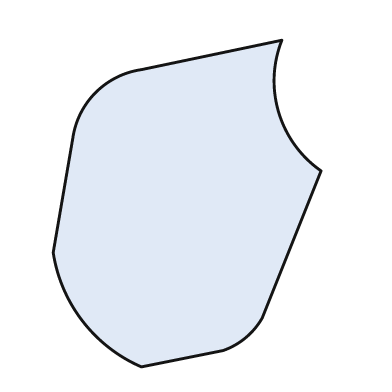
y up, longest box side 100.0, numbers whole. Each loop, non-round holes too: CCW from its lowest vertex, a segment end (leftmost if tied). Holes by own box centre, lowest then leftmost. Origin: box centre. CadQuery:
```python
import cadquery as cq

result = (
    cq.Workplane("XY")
    .moveTo(-14.0, -50.0)
    .lineTo(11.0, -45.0)
    .threePointArc((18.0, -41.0), (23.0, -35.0))
    .lineTo(41.0, 10.0)
    .threePointArc((28.0, 28.0), (29.0, 50.0))
    .lineTo(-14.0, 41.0)
    .threePointArc((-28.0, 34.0), (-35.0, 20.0))
    .lineTo(-41.0, -15.0)
    .threePointArc((-32.0, -36.0), (-14.0, -50.0))
    .close()
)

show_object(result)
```